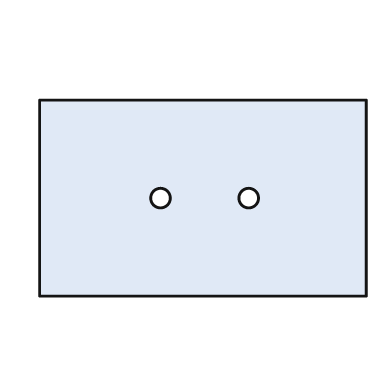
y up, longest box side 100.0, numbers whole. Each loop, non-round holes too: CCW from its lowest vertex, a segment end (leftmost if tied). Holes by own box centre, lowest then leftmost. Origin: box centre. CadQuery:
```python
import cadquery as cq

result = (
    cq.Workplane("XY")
    .moveTo(-50.0, -30.0)
    .lineTo(50.0, -30.0)
    .lineTo(50.0, 30.0)
    .lineTo(-50.0, 30.0)
    .close()
    .moveTo(-13.0, 0.0)
    .circle(3.0)
    .moveTo(14.0, 0.0)
    .circle(3.0)
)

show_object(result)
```